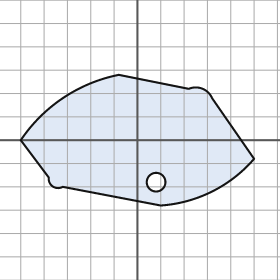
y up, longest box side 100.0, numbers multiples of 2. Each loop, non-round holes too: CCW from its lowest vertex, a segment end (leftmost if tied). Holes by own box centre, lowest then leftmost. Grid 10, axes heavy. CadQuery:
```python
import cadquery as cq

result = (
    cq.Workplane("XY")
    .moveTo(10.0, -28.0)
    .threePointArc((32.0, -22.0), (50.0, -8.0))
    .lineTo(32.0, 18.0)
    .threePointArc((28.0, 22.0), (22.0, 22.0))
    .lineTo(-8.0, 28.0)
    .threePointArc((-32.0, 18.0), (-50.0, 0.0))
    .lineTo(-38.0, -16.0)
    .threePointArc((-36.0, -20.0), (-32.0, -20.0))
    .close()
    .moveTo(8.0, -18.0)
    .circle(4.0)
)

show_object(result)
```